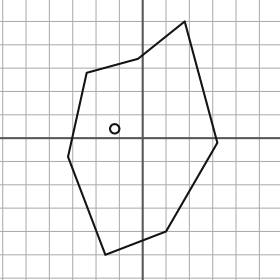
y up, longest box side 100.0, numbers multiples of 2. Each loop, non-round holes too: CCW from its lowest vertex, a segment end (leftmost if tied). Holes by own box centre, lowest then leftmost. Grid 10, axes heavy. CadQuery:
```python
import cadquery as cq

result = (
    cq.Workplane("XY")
    .moveTo(-16.0, -50.0)
    .lineTo(10.0, -40.0)
    .lineTo(32.0, -2.0)
    .lineTo(18.0, 50.0)
    .lineTo(-2.0, 34.0)
    .lineTo(-24.0, 28.0)
    .lineTo(-32.0, -8.0)
    .close()
    .moveTo(-12.0, 4.0)
    .circle(2.0)
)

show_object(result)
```